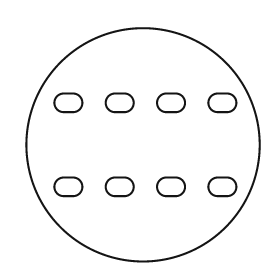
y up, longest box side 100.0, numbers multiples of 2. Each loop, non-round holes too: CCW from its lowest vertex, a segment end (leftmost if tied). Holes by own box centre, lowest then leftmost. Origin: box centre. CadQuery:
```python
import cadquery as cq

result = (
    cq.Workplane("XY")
    .moveTo(0.0, 0.0)
    .circle(50.0)
    .moveTo(-34.0, -22.0)
    .lineTo(-30.0, -22.0)
    .threePointArc((-26.0, -18.0), (-30.0, -14.0))
    .lineTo(-34.0, -14.0)
    .threePointArc((-38.0, -18.0), (-34.0, -22.0))
    .close()
    .moveTo(-12.0, -22.0)
    .lineTo(-8.0, -22.0)
    .threePointArc((-4.0, -18.0), (-8.0, -14.0))
    .lineTo(-12.0, -14.0)
    .threePointArc((-16.0, -18.0), (-12.0, -22.0))
    .close()
    .moveTo(10.0, -22.0)
    .lineTo(14.0, -22.0)
    .threePointArc((18.0, -18.0), (14.0, -14.0))
    .lineTo(10.0, -14.0)
    .threePointArc((6.0, -18.0), (10.0, -22.0))
    .close()
    .moveTo(32.0, -22.0)
    .lineTo(36.0, -22.0)
    .threePointArc((40.0, -18.0), (36.0, -14.0))
    .lineTo(32.0, -14.0)
    .threePointArc((28.0, -18.0), (32.0, -22.0))
    .close()
    .moveTo(-34.0, 14.0)
    .lineTo(-30.0, 14.0)
    .threePointArc((-26.0, 18.0), (-30.0, 22.0))
    .lineTo(-34.0, 22.0)
    .threePointArc((-38.0, 18.0), (-34.0, 14.0))
    .close()
    .moveTo(-12.0, 14.0)
    .lineTo(-8.0, 14.0)
    .threePointArc((-4.0, 18.0), (-8.0, 22.0))
    .lineTo(-12.0, 22.0)
    .threePointArc((-16.0, 18.0), (-12.0, 14.0))
    .close()
    .moveTo(10.0, 14.0)
    .lineTo(14.0, 14.0)
    .threePointArc((18.0, 18.0), (14.0, 22.0))
    .lineTo(10.0, 22.0)
    .threePointArc((6.0, 18.0), (10.0, 14.0))
    .close()
    .moveTo(32.0, 14.0)
    .lineTo(36.0, 14.0)
    .threePointArc((40.0, 18.0), (36.0, 22.0))
    .lineTo(32.0, 22.0)
    .threePointArc((28.0, 18.0), (32.0, 14.0))
    .close()
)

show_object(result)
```